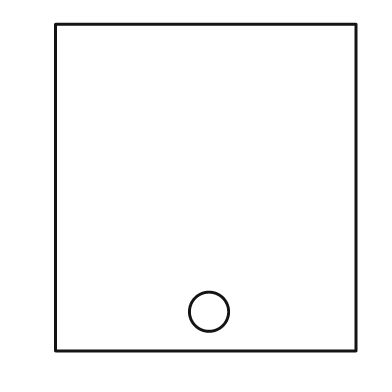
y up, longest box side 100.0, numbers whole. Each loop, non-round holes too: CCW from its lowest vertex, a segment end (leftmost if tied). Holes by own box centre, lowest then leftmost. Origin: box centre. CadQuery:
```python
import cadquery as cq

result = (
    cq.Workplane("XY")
    .moveTo(-46.0, -50.0)
    .lineTo(46.0, -50.0)
    .lineTo(46.0, 50.0)
    .lineTo(-46.0, 50.0)
    .close()
    .moveTo(1.0, -38.0)
    .circle(6.0)
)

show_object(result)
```